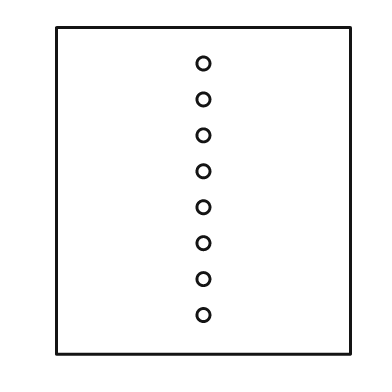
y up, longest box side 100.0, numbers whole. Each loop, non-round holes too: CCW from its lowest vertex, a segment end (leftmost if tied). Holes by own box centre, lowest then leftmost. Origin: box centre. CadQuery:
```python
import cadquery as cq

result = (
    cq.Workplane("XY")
    .moveTo(-45.0, -50.0)
    .lineTo(45.0, -50.0)
    .lineTo(45.0, 50.0)
    .lineTo(-45.0, 50.0)
    .close()
    .moveTo(0.0, -38.0)
    .circle(2.0)
    .moveTo(0.0, -27.0)
    .circle(2.0)
    .moveTo(0.0, -16.0)
    .circle(2.0)
    .moveTo(0.0, -5.0)
    .circle(2.0)
    .moveTo(0.0, 6.0)
    .circle(2.0)
    .moveTo(0.0, 17.0)
    .circle(2.0)
    .moveTo(0.0, 28.0)
    .circle(2.0)
    .moveTo(0.0, 39.0)
    .circle(2.0)
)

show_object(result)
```